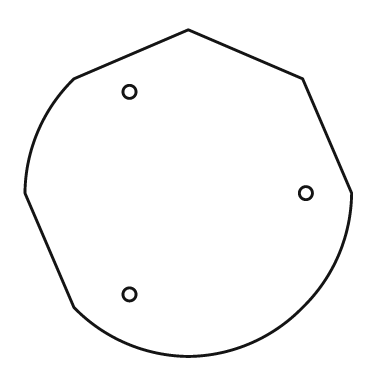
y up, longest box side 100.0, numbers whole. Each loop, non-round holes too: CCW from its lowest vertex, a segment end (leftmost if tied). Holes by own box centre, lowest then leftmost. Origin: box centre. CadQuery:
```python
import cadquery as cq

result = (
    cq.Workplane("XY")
    .moveTo(0.0, -50.0)
    .threePointArc((19.0, -46.0), (35.0, -35.0))
    .threePointArc((46.0, -19.0), (50.0, 0.0))
    .lineTo(35.0, 35.0)
    .lineTo(0.0, 50.0)
    .lineTo(-35.0, 35.0)
    .threePointArc((-46.0, 19.0), (-50.0, 0.0))
    .lineTo(-35.0, -35.0)
    .threePointArc((-19.0, -46.0), (0.0, -50.0))
    .close()
    .moveTo(-18.0, -31.0)
    .circle(2.0)
    .moveTo(36.0, 0.0)
    .circle(2.0)
    .moveTo(-18.0, 31.0)
    .circle(2.0)
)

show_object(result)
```